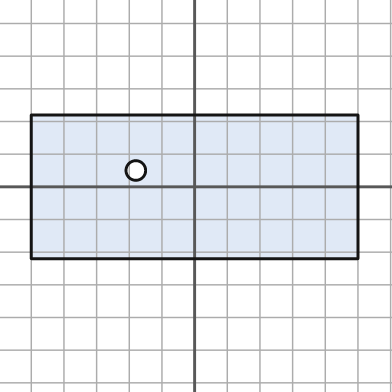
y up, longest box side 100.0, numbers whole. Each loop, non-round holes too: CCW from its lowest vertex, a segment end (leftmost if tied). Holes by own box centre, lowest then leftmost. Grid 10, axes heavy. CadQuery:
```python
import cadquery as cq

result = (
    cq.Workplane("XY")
    .moveTo(-50.0, -22.0)
    .lineTo(50.0, -22.0)
    .lineTo(50.0, 22.0)
    .lineTo(-50.0, 22.0)
    .close()
    .moveTo(-18.0, 5.0)
    .circle(3.0)
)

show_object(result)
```